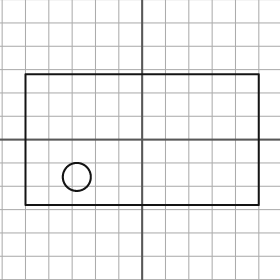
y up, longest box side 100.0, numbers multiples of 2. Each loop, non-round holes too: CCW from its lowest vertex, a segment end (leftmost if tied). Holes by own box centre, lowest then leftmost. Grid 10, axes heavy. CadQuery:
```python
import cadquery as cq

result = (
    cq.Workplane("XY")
    .moveTo(-50.0, -28.0)
    .lineTo(50.0, -28.0)
    .lineTo(50.0, 28.0)
    .lineTo(-50.0, 28.0)
    .close()
    .moveTo(-28.0, -16.0)
    .circle(6.0)
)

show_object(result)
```